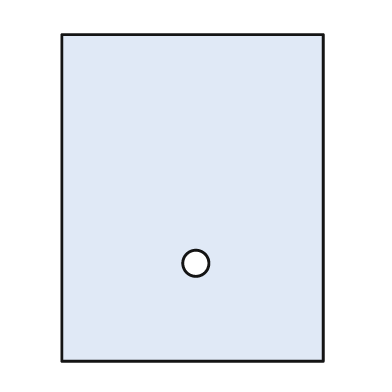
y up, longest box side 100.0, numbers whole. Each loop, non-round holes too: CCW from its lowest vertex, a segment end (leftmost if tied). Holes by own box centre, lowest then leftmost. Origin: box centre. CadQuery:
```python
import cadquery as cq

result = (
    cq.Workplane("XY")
    .moveTo(-40.0, -50.0)
    .lineTo(40.0, -50.0)
    .lineTo(40.0, 50.0)
    .lineTo(-40.0, 50.0)
    .close()
    .moveTo(1.0, -20.0)
    .circle(4.0)
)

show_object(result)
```